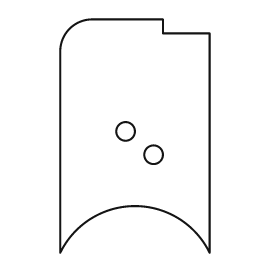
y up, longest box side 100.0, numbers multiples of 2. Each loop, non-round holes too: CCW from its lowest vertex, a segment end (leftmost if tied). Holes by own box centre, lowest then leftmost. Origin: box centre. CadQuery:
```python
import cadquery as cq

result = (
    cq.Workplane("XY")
    .moveTo(-32.0, -50.0)
    .threePointArc((0.0, -30.0), (32.0, -50.0))
    .lineTo(32.0, 44.0)
    .lineTo(12.0, 44.0)
    .lineTo(12.0, 50.0)
    .lineTo(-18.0, 50.0)
    .threePointArc((-28.0, 46.0), (-32.0, 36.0))
    .close()
    .moveTo(8.0, -8.0)
    .circle(4.0)
    .moveTo(-4.0, 2.0)
    .circle(4.0)
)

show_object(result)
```